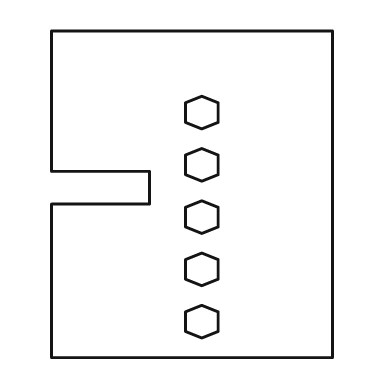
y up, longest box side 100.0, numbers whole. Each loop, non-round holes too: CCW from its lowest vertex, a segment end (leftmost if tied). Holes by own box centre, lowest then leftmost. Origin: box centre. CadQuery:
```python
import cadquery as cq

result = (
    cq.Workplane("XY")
    .moveTo(-43.0, -50.0)
    .lineTo(43.0, -50.0)
    .lineTo(43.0, 50.0)
    .lineTo(-43.0, 50.0)
    .lineTo(-43.0, 7.0)
    .lineTo(-13.0, 7.0)
    .lineTo(-13.0, -3.0)
    .lineTo(-43.0, -3.0)
    .close()
    .moveTo(3.0, -44.0)
    .lineTo(8.0, -42.0)
    .lineTo(8.0, -36.0)
    .lineTo(3.0, -34.0)
    .lineTo(-2.0, -36.0)
    .lineTo(-2.0, -42.0)
    .close()
    .moveTo(3.0, -28.0)
    .lineTo(8.0, -26.0)
    .lineTo(8.0, -20.0)
    .lineTo(3.0, -18.0)
    .lineTo(-2.0, -20.0)
    .lineTo(-2.0, -26.0)
    .close()
    .moveTo(3.0, -12.0)
    .lineTo(8.0, -10.0)
    .lineTo(8.0, -4.0)
    .lineTo(3.0, -2.0)
    .lineTo(-2.0, -4.0)
    .lineTo(-2.0, -10.0)
    .close()
    .moveTo(3.0, 4.0)
    .lineTo(8.0, 6.0)
    .lineTo(8.0, 12.0)
    .lineTo(3.0, 14.0)
    .lineTo(-2.0, 12.0)
    .lineTo(-2.0, 6.0)
    .close()
    .moveTo(3.0, 20.0)
    .lineTo(8.0, 22.0)
    .lineTo(8.0, 28.0)
    .lineTo(3.0, 30.0)
    .lineTo(-2.0, 28.0)
    .lineTo(-2.0, 22.0)
    .close()
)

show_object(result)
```